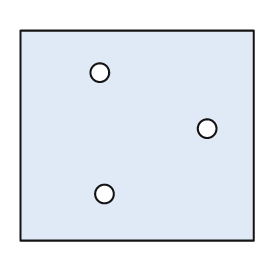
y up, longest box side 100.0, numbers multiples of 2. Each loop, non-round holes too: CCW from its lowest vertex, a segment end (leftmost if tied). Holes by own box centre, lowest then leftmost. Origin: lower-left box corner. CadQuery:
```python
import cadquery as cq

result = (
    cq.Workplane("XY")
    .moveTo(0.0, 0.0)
    .lineTo(100.0, 0.0)
    .lineTo(100.0, 90.0)
    .lineTo(0.0, 90.0)
    .close()
    .moveTo(36.0, 20.0)
    .circle(4.0)
    .moveTo(80.0, 48.0)
    .circle(4.0)
    .moveTo(34.0, 72.0)
    .circle(4.0)
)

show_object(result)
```